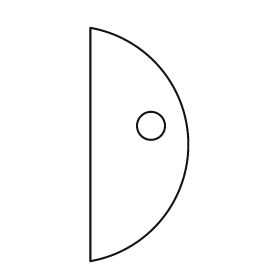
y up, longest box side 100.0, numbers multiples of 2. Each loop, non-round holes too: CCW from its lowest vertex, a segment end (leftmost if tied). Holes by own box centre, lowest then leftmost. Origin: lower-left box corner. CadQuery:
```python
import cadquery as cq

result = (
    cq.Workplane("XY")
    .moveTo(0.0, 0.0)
    .threePointArc((42.0, 50.0), (0.0, 100.0))
    .close()
    .moveTo(26.0, 58.0)
    .circle(6.0)
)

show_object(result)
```